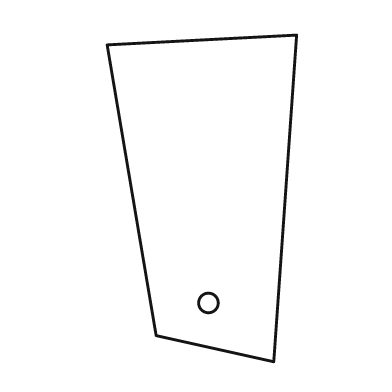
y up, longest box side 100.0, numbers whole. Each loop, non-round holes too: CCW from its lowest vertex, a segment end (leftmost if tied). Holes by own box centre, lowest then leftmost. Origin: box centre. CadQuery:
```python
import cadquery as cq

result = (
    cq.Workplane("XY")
    .moveTo(22.0, -50.0)
    .lineTo(29.0, 50.0)
    .lineTo(-29.0, 47.0)
    .lineTo(-14.0, -42.0)
    .close()
    .moveTo(2.0, -32.0)
    .circle(3.0)
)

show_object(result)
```